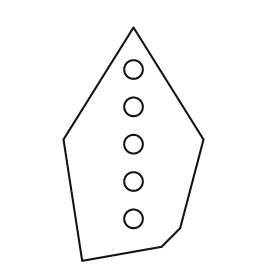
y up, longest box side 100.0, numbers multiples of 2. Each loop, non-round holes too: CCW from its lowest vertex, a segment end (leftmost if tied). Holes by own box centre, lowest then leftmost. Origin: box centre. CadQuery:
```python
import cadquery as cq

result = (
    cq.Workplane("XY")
    .moveTo(-22.0, -50.0)
    .lineTo(12.0, -44.0)
    .lineTo(20.0, -36.0)
    .lineTo(30.0, 2.0)
    .lineTo(0.0, 50.0)
    .lineTo(-30.0, 2.0)
    .close()
    .moveTo(0.0, -32.0)
    .circle(4.0)
    .moveTo(0.0, -16.0)
    .circle(4.0)
    .moveTo(0.0, 0.0)
    .circle(4.0)
    .moveTo(0.0, 16.0)
    .circle(4.0)
    .moveTo(0.0, 32.0)
    .circle(4.0)
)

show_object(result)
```